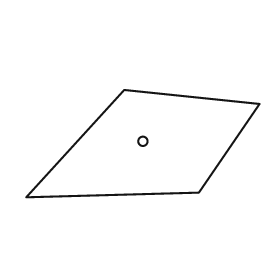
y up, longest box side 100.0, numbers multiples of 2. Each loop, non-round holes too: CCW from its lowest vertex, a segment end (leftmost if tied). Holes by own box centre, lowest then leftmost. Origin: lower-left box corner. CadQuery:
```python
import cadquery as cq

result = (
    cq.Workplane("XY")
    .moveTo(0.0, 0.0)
    .lineTo(74.0, 2.0)
    .lineTo(100.0, 40.0)
    .lineTo(42.0, 46.0)
    .close()
    .moveTo(50.0, 24.0)
    .circle(2.0)
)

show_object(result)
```